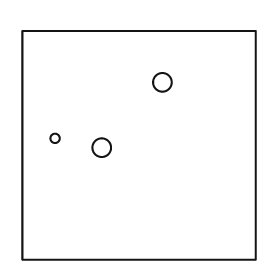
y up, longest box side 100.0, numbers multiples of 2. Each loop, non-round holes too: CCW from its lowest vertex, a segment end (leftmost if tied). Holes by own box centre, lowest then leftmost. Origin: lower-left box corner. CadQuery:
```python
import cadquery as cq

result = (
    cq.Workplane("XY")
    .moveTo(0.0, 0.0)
    .lineTo(100.0, 0.0)
    .lineTo(100.0, 98.0)
    .lineTo(0.0, 98.0)
    .close()
    .moveTo(34.0, 48.0)
    .circle(4.0)
    .moveTo(14.0, 52.0)
    .circle(2.0)
    .moveTo(60.0, 76.0)
    .circle(4.0)
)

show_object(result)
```